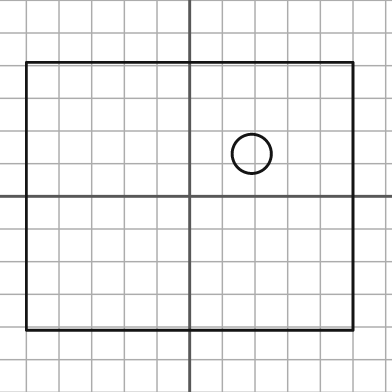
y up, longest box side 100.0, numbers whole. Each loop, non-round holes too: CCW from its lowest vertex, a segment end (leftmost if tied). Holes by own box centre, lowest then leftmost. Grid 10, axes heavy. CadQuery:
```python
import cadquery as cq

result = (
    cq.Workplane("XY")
    .moveTo(-50.0, -41.0)
    .lineTo(50.0, -41.0)
    .lineTo(50.0, 41.0)
    .lineTo(-50.0, 41.0)
    .close()
    .moveTo(19.0, 13.0)
    .circle(6.0)
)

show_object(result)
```